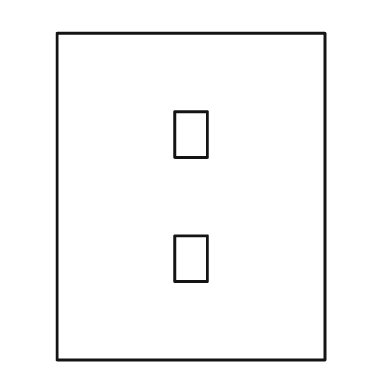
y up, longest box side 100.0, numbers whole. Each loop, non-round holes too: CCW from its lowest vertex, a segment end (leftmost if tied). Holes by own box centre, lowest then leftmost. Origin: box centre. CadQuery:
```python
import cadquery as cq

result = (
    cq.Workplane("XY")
    .moveTo(-41.0, -50.0)
    .lineTo(41.0, -50.0)
    .lineTo(41.0, 50.0)
    .lineTo(-41.0, 50.0)
    .close()
    .moveTo(-5.0, -26.0)
    .lineTo(5.0, -26.0)
    .lineTo(5.0, -12.0)
    .lineTo(-5.0, -12.0)
    .close()
    .moveTo(-5.0, 12.0)
    .lineTo(5.0, 12.0)
    .lineTo(5.0, 26.0)
    .lineTo(-5.0, 26.0)
    .close()
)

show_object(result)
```